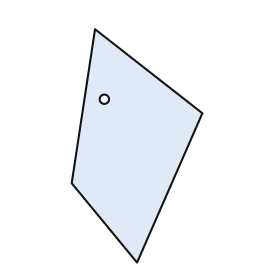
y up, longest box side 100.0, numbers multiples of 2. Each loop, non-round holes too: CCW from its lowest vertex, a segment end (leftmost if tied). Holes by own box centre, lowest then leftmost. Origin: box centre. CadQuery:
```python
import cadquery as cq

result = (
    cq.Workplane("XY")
    .moveTo(0.0, -50.0)
    .lineTo(28.0, 14.0)
    .lineTo(-18.0, 50.0)
    .lineTo(-28.0, -16.0)
    .close()
    .moveTo(-14.0, 20.0)
    .circle(2.0)
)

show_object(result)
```